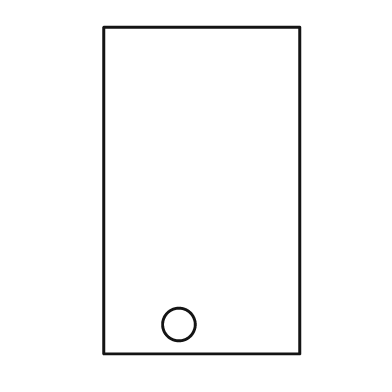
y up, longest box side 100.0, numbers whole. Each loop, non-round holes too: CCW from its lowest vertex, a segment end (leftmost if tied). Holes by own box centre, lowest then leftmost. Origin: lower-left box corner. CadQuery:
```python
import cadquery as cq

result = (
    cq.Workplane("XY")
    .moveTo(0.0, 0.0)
    .lineTo(60.0, 0.0)
    .lineTo(60.0, 100.0)
    .lineTo(0.0, 100.0)
    .close()
    .moveTo(23.0, 9.0)
    .circle(5.0)
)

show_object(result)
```